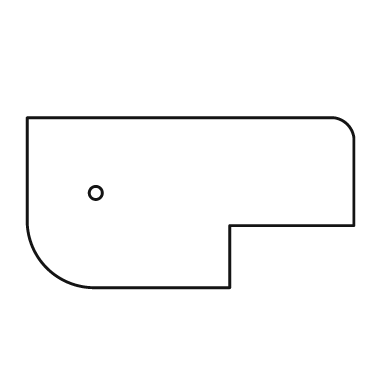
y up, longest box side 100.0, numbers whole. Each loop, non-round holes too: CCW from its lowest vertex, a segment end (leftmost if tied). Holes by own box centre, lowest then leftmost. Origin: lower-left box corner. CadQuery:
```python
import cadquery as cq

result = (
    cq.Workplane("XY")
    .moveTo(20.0, 0.0)
    .lineTo(62.0, 0.0)
    .lineTo(62.0, 19.0)
    .lineTo(100.0, 19.0)
    .lineTo(100.0, 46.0)
    .threePointArc((98.0, 50.0), (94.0, 52.0))
    .lineTo(0.0, 52.0)
    .lineTo(0.0, 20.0)
    .threePointArc((6.0, 6.0), (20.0, 0.0))
    .close()
    .moveTo(21.0, 29.0)
    .circle(2.0)
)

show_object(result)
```